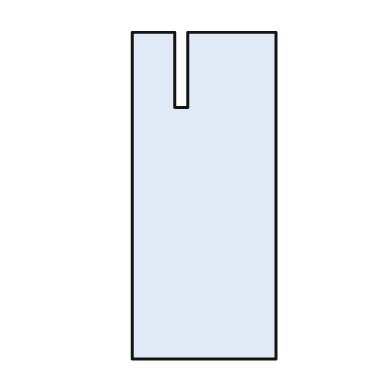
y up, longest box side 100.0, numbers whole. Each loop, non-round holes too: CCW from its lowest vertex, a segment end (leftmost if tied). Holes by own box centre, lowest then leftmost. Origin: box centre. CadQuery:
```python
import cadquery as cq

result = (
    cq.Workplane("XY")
    .moveTo(-22.0, -50.0)
    .lineTo(22.0, -50.0)
    .lineTo(22.0, 50.0)
    .lineTo(-5.0, 50.0)
    .lineTo(-5.0, 27.0)
    .lineTo(-9.0, 27.0)
    .lineTo(-9.0, 50.0)
    .lineTo(-22.0, 50.0)
    .close()
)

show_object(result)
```